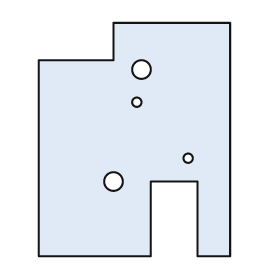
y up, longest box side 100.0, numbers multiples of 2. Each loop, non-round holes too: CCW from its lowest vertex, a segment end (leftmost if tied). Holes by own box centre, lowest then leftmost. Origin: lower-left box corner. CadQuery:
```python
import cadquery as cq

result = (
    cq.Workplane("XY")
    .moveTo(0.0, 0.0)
    .lineTo(48.0, 0.0)
    .lineTo(48.0, 32.0)
    .lineTo(68.0, 32.0)
    .lineTo(68.0, 0.0)
    .lineTo(82.0, 0.0)
    .lineTo(82.0, 100.0)
    .lineTo(32.0, 100.0)
    .lineTo(32.0, 84.0)
    .lineTo(0.0, 84.0)
    .close()
    .moveTo(32.0, 32.0)
    .circle(4.0)
    .moveTo(64.0, 42.0)
    .circle(2.0)
    .moveTo(42.0, 66.0)
    .circle(2.0)
    .moveTo(44.0, 80.0)
    .circle(4.0)
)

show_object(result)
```